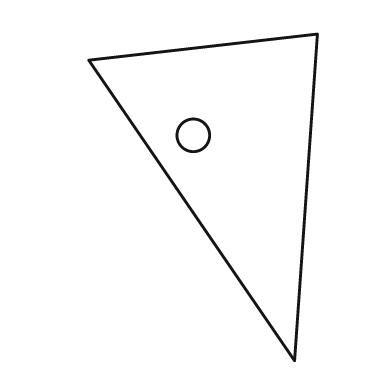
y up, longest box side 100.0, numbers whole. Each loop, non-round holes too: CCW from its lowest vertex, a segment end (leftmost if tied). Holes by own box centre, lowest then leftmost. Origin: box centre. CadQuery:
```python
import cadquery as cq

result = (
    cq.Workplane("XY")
    .moveTo(28.0, -50.0)
    .lineTo(35.0, 50.0)
    .lineTo(-35.0, 42.0)
    .close()
    .moveTo(-3.0, 19.0)
    .circle(5.0)
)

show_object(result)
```